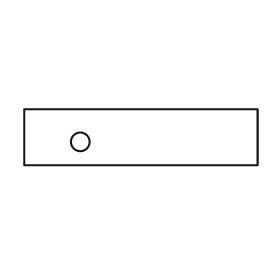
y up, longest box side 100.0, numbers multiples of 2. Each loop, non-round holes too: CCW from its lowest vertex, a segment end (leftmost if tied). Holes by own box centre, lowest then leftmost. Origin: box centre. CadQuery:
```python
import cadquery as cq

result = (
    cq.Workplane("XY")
    .moveTo(-50.0, -12.0)
    .lineTo(50.0, -12.0)
    .lineTo(50.0, 12.0)
    .lineTo(-50.0, 12.0)
    .close()
    .moveTo(-26.0, -2.0)
    .circle(4.0)
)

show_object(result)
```